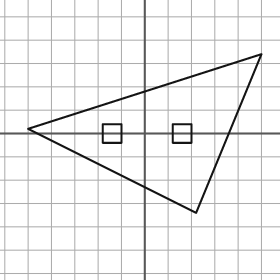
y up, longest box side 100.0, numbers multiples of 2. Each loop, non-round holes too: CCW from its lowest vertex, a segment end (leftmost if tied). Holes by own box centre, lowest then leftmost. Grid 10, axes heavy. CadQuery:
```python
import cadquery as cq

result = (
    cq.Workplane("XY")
    .moveTo(22.0, -34.0)
    .lineTo(50.0, 34.0)
    .lineTo(-50.0, 2.0)
    .close()
    .moveTo(-18.0, -4.0)
    .lineTo(-10.0, -4.0)
    .lineTo(-10.0, 4.0)
    .lineTo(-18.0, 4.0)
    .close()
    .moveTo(12.0, -4.0)
    .lineTo(20.0, -4.0)
    .lineTo(20.0, 4.0)
    .lineTo(12.0, 4.0)
    .close()
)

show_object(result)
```